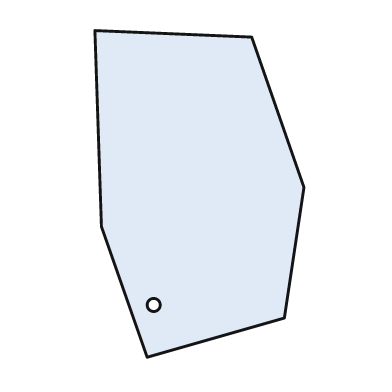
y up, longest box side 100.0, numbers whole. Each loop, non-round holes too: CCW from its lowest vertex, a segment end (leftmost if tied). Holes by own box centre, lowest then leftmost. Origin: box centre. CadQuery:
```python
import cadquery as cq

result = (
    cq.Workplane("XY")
    .moveTo(-16.0, -50.0)
    .lineTo(26.0, -38.0)
    .lineTo(32.0, 2.0)
    .lineTo(16.0, 48.0)
    .lineTo(-32.0, 50.0)
    .lineTo(-30.0, -10.0)
    .close()
    .moveTo(-14.0, -34.0)
    .circle(2.0)
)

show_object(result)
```